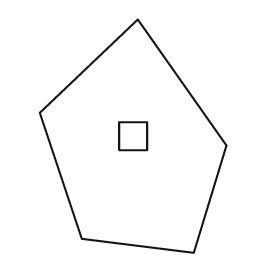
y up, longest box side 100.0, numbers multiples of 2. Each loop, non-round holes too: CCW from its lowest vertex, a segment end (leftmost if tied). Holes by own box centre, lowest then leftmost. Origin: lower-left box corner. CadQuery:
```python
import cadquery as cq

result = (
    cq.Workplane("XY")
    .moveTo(66.0, 0.0)
    .lineTo(80.0, 46.0)
    .lineTo(42.0, 100.0)
    .lineTo(0.0, 60.0)
    .lineTo(18.0, 6.0)
    .close()
    .moveTo(34.0, 44.0)
    .lineTo(46.0, 44.0)
    .lineTo(46.0, 56.0)
    .lineTo(34.0, 56.0)
    .close()
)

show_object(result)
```